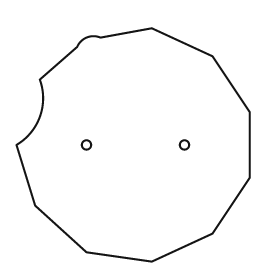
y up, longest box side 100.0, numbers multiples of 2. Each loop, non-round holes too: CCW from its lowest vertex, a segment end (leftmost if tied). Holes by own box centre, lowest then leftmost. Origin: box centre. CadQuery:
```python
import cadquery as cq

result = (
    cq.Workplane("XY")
    .moveTo(8.0, -50.0)
    .lineTo(34.0, -38.0)
    .lineTo(50.0, -14.0)
    .lineTo(50.0, 14.0)
    .lineTo(34.0, 38.0)
    .lineTo(8.0, 50.0)
    .lineTo(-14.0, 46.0)
    .threePointArc((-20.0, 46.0), (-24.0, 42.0))
    .lineTo(-40.0, 28.0)
    .threePointArc((-40.0, 12.0), (-50.0, 0.0))
    .lineTo(-42.0, -26.0)
    .lineTo(-20.0, -46.0)
    .close()
    .moveTo(-20.0, 0.0)
    .circle(2.0)
    .moveTo(22.0, 0.0)
    .circle(2.0)
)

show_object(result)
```